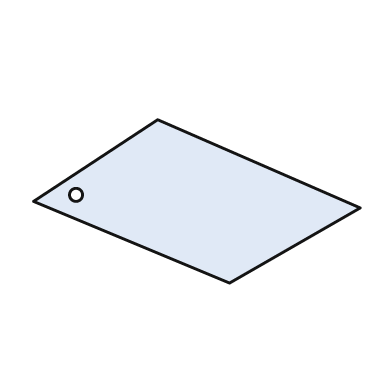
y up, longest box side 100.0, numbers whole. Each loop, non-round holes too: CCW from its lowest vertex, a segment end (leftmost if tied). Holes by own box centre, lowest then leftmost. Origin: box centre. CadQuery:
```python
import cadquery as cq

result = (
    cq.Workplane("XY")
    .moveTo(10.0, -25.0)
    .lineTo(50.0, -2.0)
    .lineTo(-12.0, 25.0)
    .lineTo(-50.0, 0.0)
    .close()
    .moveTo(-37.0, 2.0)
    .circle(2.0)
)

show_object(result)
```